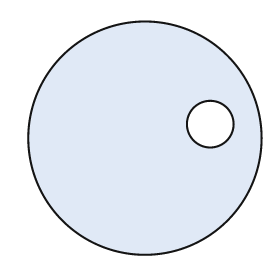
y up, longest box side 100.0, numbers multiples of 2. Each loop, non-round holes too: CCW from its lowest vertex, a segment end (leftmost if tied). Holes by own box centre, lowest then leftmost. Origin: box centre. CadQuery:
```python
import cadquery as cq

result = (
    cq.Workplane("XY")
    .moveTo(0.0, 0.0)
    .circle(50.0)
    .moveTo(28.0, 6.0)
    .circle(10.0)
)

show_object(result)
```